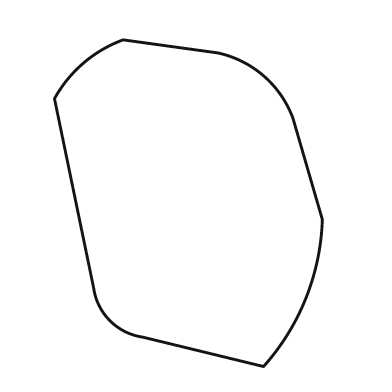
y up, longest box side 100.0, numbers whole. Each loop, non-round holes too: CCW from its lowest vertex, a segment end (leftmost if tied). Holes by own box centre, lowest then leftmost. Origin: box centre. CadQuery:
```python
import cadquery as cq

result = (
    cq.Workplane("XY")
    .moveTo(23.0, -50.0)
    .threePointArc((36.0, -29.0), (41.0, -5.0))
    .lineTo(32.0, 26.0)
    .threePointArc((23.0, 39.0), (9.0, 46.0))
    .lineTo(-20.0, 50.0)
    .threePointArc((-32.0, 43.0), (-41.0, 32.0))
    .lineTo(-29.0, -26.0)
    .threePointArc((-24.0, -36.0), (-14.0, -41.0))
    .close()
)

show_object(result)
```